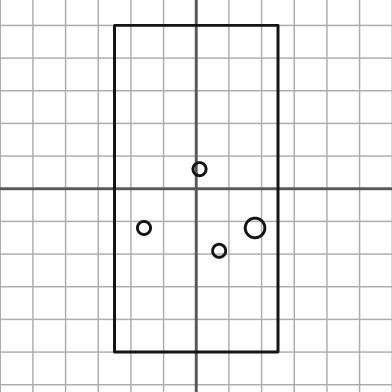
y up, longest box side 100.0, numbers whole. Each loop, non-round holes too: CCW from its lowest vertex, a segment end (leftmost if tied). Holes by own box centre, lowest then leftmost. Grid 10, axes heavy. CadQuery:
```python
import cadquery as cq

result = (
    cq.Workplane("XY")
    .moveTo(-25.0, -50.0)
    .lineTo(25.0, -50.0)
    .lineTo(25.0, 50.0)
    .lineTo(-25.0, 50.0)
    .close()
    .moveTo(7.0, -19.0)
    .circle(2.0)
    .moveTo(-16.0, -12.0)
    .circle(2.0)
    .moveTo(18.0, -12.0)
    .circle(3.0)
    .moveTo(1.0, 6.0)
    .circle(2.0)
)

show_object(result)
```